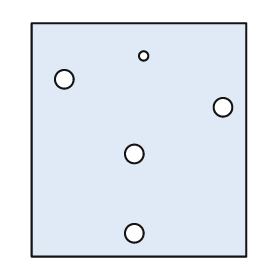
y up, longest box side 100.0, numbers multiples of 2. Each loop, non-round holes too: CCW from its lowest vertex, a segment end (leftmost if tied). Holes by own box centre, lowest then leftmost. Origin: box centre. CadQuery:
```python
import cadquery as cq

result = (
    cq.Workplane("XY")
    .moveTo(-46.0, -50.0)
    .lineTo(46.0, -50.0)
    .lineTo(46.0, 50.0)
    .lineTo(-46.0, 50.0)
    .close()
    .moveTo(-2.0, -40.0)
    .circle(4.0)
    .moveTo(-2.0, -6.0)
    .circle(4.0)
    .moveTo(36.0, 14.0)
    .circle(4.0)
    .moveTo(-32.0, 26.0)
    .circle(4.0)
    .moveTo(2.0, 36.0)
    .circle(2.0)
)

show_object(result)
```